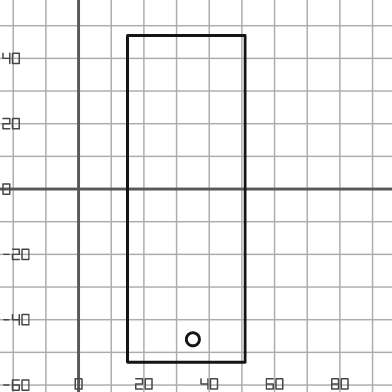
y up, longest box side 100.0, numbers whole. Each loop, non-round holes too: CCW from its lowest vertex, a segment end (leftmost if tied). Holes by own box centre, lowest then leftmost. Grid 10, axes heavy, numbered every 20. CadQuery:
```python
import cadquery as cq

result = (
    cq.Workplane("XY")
    .moveTo(15.0, -53.0)
    .lineTo(51.0, -53.0)
    .lineTo(51.0, 47.0)
    .lineTo(15.0, 47.0)
    .close()
    .moveTo(35.0, -46.0)
    .circle(2.0)
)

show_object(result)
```